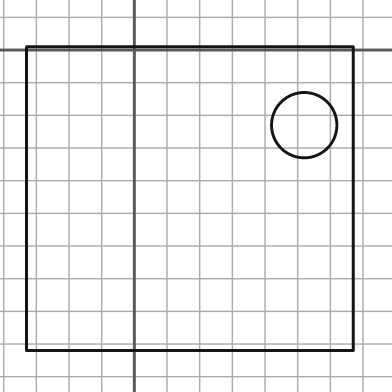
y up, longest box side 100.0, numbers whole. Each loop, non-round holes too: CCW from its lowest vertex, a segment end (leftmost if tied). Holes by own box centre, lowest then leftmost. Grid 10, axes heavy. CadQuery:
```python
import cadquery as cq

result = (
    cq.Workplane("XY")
    .moveTo(-33.0, -92.0)
    .lineTo(67.0, -92.0)
    .lineTo(67.0, 1.0)
    .lineTo(-33.0, 1.0)
    .close()
    .moveTo(52.0, -23.0)
    .circle(10.0)
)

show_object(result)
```